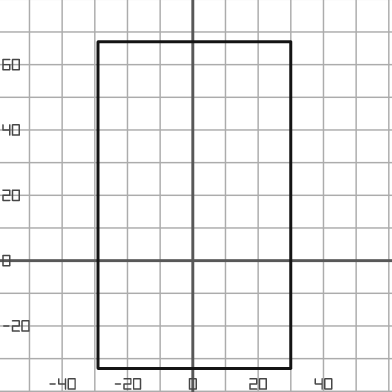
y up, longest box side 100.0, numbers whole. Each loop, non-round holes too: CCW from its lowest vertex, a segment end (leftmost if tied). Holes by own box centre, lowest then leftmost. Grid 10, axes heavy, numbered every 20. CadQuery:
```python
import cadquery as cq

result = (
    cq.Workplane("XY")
    .moveTo(-29.0, -33.0)
    .lineTo(30.0, -33.0)
    .lineTo(30.0, 67.0)
    .lineTo(-29.0, 67.0)
    .close()
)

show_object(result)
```